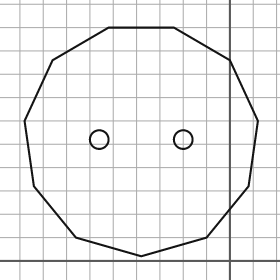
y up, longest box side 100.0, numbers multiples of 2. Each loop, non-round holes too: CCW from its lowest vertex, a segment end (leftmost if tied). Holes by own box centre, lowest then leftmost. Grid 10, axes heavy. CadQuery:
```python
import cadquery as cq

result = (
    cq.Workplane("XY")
    .moveTo(-38.0, 2.0)
    .lineTo(-10.0, 10.0)
    .lineTo(8.0, 32.0)
    .lineTo(12.0, 60.0)
    .lineTo(0.0, 86.0)
    .lineTo(-24.0, 100.0)
    .lineTo(-52.0, 100.0)
    .lineTo(-76.0, 86.0)
    .lineTo(-88.0, 60.0)
    .lineTo(-84.0, 32.0)
    .lineTo(-66.0, 10.0)
    .close()
    .moveTo(-56.0, 52.0)
    .circle(4.0)
    .moveTo(-20.0, 52.0)
    .circle(4.0)
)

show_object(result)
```